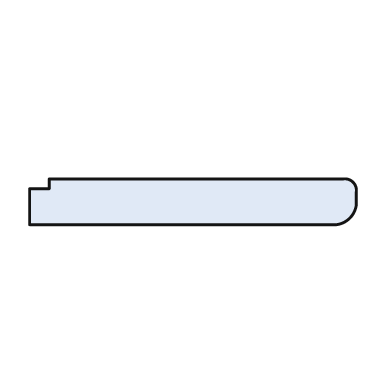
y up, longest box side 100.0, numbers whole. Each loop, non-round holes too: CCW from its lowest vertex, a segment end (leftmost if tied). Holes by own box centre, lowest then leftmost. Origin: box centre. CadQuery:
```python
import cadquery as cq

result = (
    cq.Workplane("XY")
    .moveTo(-50.0, -7.0)
    .lineTo(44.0, -7.0)
    .threePointArc((48.0, -5.0), (50.0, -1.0))
    .lineTo(50.0, 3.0)
    .threePointArc((49.0, 6.0), (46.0, 7.0))
    .lineTo(-44.0, 7.0)
    .lineTo(-44.0, 4.0)
    .lineTo(-50.0, 4.0)
    .close()
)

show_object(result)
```